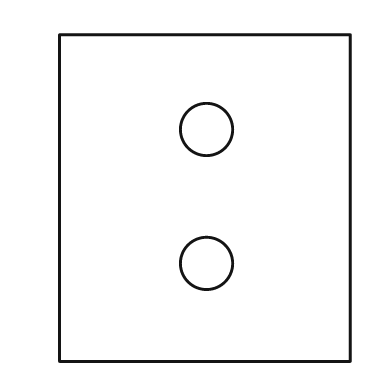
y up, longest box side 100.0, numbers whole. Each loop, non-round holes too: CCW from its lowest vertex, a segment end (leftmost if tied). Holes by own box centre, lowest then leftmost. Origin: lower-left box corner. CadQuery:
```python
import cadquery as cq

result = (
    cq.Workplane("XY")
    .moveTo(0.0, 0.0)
    .lineTo(89.0, 0.0)
    .lineTo(89.0, 100.0)
    .lineTo(0.0, 100.0)
    .close()
    .moveTo(45.0, 30.0)
    .circle(8.0)
    .moveTo(45.0, 71.0)
    .circle(8.0)
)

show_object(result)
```